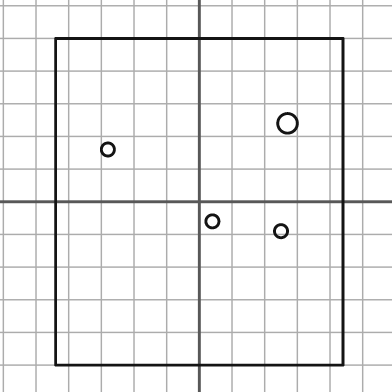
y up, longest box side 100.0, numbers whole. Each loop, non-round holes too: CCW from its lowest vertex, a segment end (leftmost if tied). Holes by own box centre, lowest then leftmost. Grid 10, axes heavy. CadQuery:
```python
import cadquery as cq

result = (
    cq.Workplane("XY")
    .moveTo(-44.0, -50.0)
    .lineTo(44.0, -50.0)
    .lineTo(44.0, 50.0)
    .lineTo(-44.0, 50.0)
    .close()
    .moveTo(25.0, -9.0)
    .circle(2.0)
    .moveTo(4.0, -6.0)
    .circle(2.0)
    .moveTo(-28.0, 16.0)
    .circle(2.0)
    .moveTo(27.0, 24.0)
    .circle(3.0)
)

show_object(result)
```